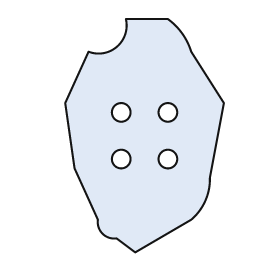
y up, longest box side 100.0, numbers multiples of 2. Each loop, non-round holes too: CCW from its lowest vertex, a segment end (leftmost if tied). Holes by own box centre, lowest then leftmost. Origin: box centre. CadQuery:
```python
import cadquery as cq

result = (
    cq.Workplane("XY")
    .moveTo(-4.0, -50.0)
    .lineTo(20.0, -36.0)
    .threePointArc((26.0, -28.0), (28.0, -18.0))
    .lineTo(34.0, 14.0)
    .lineTo(20.0, 36.0)
    .threePointArc((16.0, 44.0), (10.0, 50.0))
    .lineTo(-8.0, 50.0)
    .threePointArc((-12.0, 38.0), (-24.0, 36.0))
    .lineTo(-34.0, 14.0)
    .lineTo(-30.0, -14.0)
    .lineTo(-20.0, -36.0)
    .threePointArc((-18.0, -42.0), (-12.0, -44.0))
    .close()
    .moveTo(-10.0, -10.0)
    .circle(4.0)
    .moveTo(10.0, -10.0)
    .circle(4.0)
    .moveTo(-10.0, 10.0)
    .circle(4.0)
    .moveTo(10.0, 10.0)
    .circle(4.0)
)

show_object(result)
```